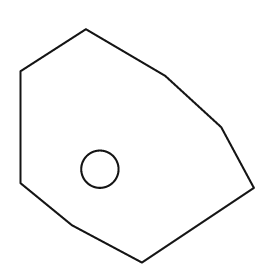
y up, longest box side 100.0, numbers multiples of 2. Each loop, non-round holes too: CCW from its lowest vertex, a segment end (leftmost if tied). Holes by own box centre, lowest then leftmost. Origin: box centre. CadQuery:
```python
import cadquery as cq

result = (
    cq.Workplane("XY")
    .moveTo(2.0, -50.0)
    .lineTo(50.0, -18.0)
    .lineTo(36.0, 8.0)
    .lineTo(12.0, 30.0)
    .lineTo(-22.0, 50.0)
    .lineTo(-50.0, 32.0)
    .lineTo(-50.0, -16.0)
    .lineTo(-28.0, -34.0)
    .close()
    .moveTo(-16.0, -10.0)
    .circle(8.0)
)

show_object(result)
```